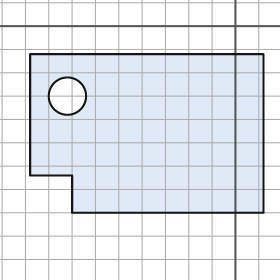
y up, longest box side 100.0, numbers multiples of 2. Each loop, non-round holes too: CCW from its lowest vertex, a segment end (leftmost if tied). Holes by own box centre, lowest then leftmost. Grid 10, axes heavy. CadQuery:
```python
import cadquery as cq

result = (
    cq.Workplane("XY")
    .moveTo(-70.0, -80.0)
    .lineTo(12.0, -80.0)
    .lineTo(12.0, -12.0)
    .lineTo(-88.0, -12.0)
    .lineTo(-88.0, -64.0)
    .lineTo(-70.0, -64.0)
    .close()
    .moveTo(-72.0, -30.0)
    .circle(8.0)
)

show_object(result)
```